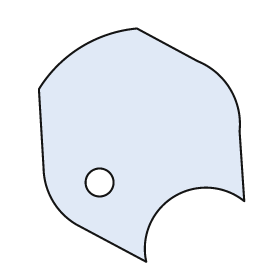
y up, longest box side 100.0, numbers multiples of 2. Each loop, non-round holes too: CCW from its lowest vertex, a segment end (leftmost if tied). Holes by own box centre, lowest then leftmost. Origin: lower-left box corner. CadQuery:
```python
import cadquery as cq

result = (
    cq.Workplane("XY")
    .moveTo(46.0, 0.0)
    .threePointArc((58.0, 28.0), (88.0, 26.0))
    .lineTo(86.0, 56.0)
    .threePointArc((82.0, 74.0), (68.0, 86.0))
    .lineTo(42.0, 100.0)
    .threePointArc((18.0, 92.0), (0.0, 74.0))
    .lineTo(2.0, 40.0)
    .threePointArc((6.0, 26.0), (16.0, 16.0))
    .close()
    .moveTo(26.0, 34.0)
    .circle(6.0)
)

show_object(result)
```